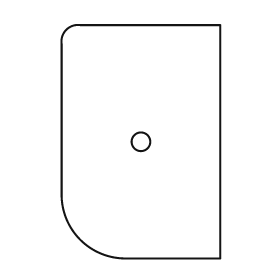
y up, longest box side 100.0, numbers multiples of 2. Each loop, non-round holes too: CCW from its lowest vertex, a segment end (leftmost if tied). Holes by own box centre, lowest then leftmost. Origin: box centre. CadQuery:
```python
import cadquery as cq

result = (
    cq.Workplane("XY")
    .moveTo(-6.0, -50.0)
    .lineTo(34.0, -50.0)
    .lineTo(34.0, 50.0)
    .lineTo(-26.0, 50.0)
    .threePointArc((-32.0, 48.0), (-34.0, 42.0))
    .lineTo(-34.0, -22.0)
    .threePointArc((-26.0, -42.0), (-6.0, -50.0))
    .close()
    .moveTo(0.0, 0.0)
    .circle(4.0)
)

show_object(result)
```